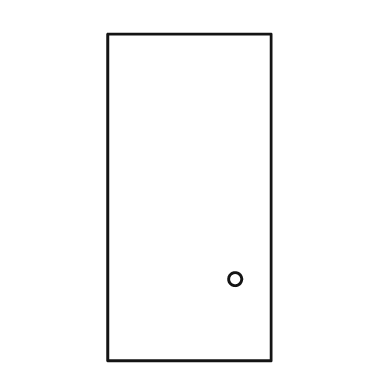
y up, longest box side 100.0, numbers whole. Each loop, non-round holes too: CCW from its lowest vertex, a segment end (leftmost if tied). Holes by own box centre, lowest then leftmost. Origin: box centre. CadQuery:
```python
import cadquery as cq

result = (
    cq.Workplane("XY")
    .moveTo(-25.0, -50.0)
    .lineTo(25.0, -50.0)
    .lineTo(25.0, 50.0)
    .lineTo(-25.0, 50.0)
    .close()
    .moveTo(14.0, -25.0)
    .circle(2.0)
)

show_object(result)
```